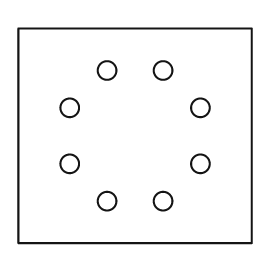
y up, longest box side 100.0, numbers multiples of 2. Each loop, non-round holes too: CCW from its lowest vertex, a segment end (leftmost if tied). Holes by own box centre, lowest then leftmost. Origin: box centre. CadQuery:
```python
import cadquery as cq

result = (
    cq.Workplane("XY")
    .moveTo(-50.0, -46.0)
    .lineTo(50.0, -46.0)
    .lineTo(50.0, 46.0)
    .lineTo(-50.0, 46.0)
    .close()
    .moveTo(-12.0, -28.0)
    .circle(4.0)
    .moveTo(12.0, -28.0)
    .circle(4.0)
    .moveTo(-28.0, -12.0)
    .circle(4.0)
    .moveTo(28.0, -12.0)
    .circle(4.0)
    .moveTo(-28.0, 12.0)
    .circle(4.0)
    .moveTo(28.0, 12.0)
    .circle(4.0)
    .moveTo(-12.0, 28.0)
    .circle(4.0)
    .moveTo(12.0, 28.0)
    .circle(4.0)
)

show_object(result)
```